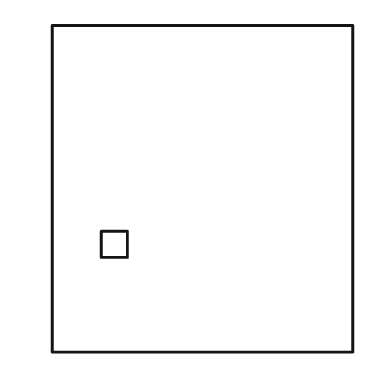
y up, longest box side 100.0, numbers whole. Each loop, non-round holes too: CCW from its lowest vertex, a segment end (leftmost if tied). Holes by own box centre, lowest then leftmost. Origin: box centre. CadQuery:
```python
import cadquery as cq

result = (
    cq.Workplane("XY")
    .moveTo(-46.0, -50.0)
    .lineTo(46.0, -50.0)
    .lineTo(46.0, 50.0)
    .lineTo(-46.0, 50.0)
    .close()
    .moveTo(-31.0, -21.0)
    .lineTo(-23.0, -21.0)
    .lineTo(-23.0, -13.0)
    .lineTo(-31.0, -13.0)
    .close()
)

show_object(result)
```